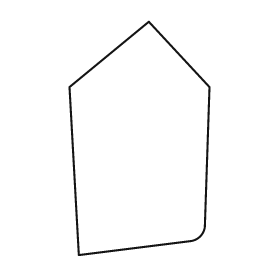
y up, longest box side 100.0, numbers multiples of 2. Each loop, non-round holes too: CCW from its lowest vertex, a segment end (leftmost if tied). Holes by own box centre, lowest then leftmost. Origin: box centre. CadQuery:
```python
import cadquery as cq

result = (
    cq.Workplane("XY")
    .moveTo(-26.0, -50.0)
    .lineTo(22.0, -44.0)
    .threePointArc((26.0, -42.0), (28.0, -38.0))
    .lineTo(30.0, 22.0)
    .lineTo(4.0, 50.0)
    .lineTo(-30.0, 22.0)
    .close()
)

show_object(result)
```